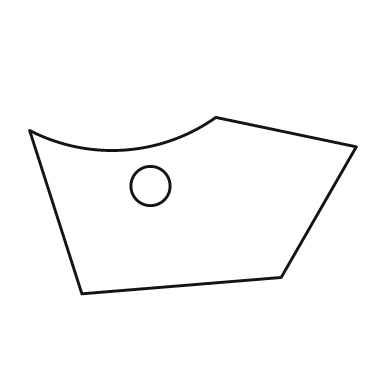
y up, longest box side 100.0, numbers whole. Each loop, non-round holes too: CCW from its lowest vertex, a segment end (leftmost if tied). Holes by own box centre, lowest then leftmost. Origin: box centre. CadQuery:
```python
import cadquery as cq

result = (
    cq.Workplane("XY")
    .moveTo(-34.0, -27.0)
    .lineTo(27.0, -22.0)
    .lineTo(50.0, 18.0)
    .lineTo(7.0, 27.0)
    .threePointArc((-21.0, 17.0), (-50.0, 23.0))
    .close()
    .moveTo(-13.0, 6.0)
    .circle(6.0)
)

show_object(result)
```